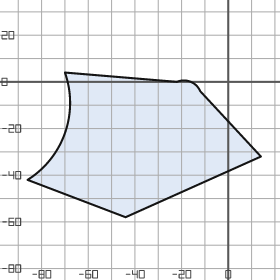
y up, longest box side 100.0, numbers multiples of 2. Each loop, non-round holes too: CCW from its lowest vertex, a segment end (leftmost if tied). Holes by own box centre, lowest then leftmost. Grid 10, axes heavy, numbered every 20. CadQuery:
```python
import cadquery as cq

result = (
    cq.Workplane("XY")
    .moveTo(-44.0, -58.0)
    .lineTo(14.0, -32.0)
    .lineTo(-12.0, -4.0)
    .threePointArc((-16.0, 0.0), (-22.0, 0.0))
    .lineTo(-70.0, 4.0)
    .threePointArc((-70.0, -22.0), (-86.0, -42.0))
    .close()
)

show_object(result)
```